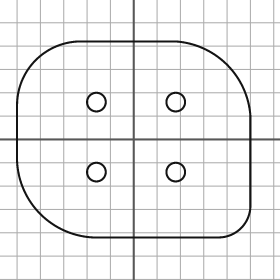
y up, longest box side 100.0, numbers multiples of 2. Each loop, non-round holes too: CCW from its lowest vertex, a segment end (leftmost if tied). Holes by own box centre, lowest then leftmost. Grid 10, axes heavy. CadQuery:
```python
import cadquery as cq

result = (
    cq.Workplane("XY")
    .moveTo(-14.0, -42.0)
    .lineTo(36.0, -42.0)
    .threePointArc((46.0, -38.0), (50.0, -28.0))
    .lineTo(50.0, 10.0)
    .threePointArc((40.0, 32.0), (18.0, 42.0))
    .lineTo(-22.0, 42.0)
    .threePointArc((-42.0, 34.0), (-50.0, 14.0))
    .lineTo(-50.0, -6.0)
    .threePointArc((-40.0, -32.0), (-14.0, -42.0))
    .close()
    .moveTo(-16.0, -14.0)
    .circle(4.0)
    .moveTo(18.0, -14.0)
    .circle(4.0)
    .moveTo(-16.0, 16.0)
    .circle(4.0)
    .moveTo(18.0, 16.0)
    .circle(4.0)
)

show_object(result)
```